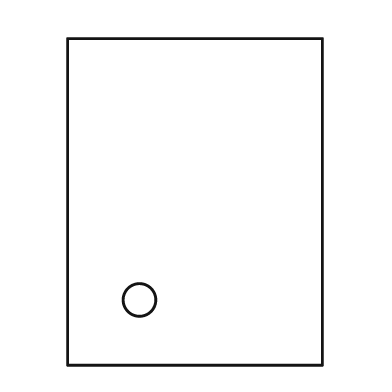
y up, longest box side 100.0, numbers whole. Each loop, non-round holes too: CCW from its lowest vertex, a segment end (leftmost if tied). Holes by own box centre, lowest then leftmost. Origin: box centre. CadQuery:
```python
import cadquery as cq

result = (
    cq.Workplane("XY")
    .moveTo(-39.0, -50.0)
    .lineTo(39.0, -50.0)
    .lineTo(39.0, 50.0)
    .lineTo(-39.0, 50.0)
    .close()
    .moveTo(-17.0, -30.0)
    .circle(5.0)
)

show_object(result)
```